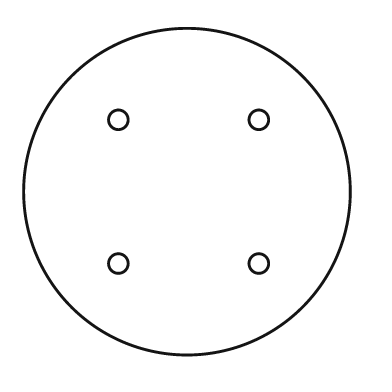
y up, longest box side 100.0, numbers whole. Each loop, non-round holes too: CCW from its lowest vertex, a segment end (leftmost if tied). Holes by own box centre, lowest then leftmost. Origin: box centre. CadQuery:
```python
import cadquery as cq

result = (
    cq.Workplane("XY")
    .moveTo(0.0, 0.0)
    .circle(50.0)
    .moveTo(-21.0, -22.0)
    .circle(3.0)
    .moveTo(22.0, -22.0)
    .circle(3.0)
    .moveTo(-21.0, 22.0)
    .circle(3.0)
    .moveTo(22.0, 22.0)
    .circle(3.0)
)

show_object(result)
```